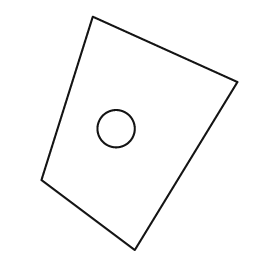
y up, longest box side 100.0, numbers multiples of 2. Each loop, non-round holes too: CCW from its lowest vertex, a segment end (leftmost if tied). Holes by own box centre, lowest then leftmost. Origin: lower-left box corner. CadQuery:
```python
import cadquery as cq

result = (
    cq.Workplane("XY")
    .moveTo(40.0, 0.0)
    .lineTo(84.0, 72.0)
    .lineTo(22.0, 100.0)
    .lineTo(0.0, 30.0)
    .close()
    .moveTo(32.0, 52.0)
    .circle(8.0)
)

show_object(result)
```